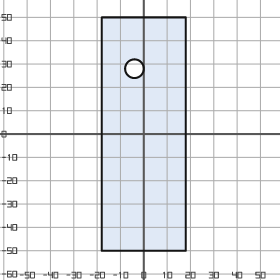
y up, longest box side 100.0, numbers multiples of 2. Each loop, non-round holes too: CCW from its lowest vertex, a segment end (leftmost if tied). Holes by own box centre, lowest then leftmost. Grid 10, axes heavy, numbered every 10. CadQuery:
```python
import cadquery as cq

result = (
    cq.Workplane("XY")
    .moveTo(-18.0, -50.0)
    .lineTo(18.0, -50.0)
    .lineTo(18.0, 50.0)
    .lineTo(-18.0, 50.0)
    .close()
    .moveTo(-4.0, 28.0)
    .circle(4.0)
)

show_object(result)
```